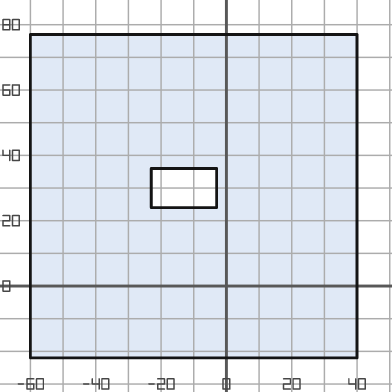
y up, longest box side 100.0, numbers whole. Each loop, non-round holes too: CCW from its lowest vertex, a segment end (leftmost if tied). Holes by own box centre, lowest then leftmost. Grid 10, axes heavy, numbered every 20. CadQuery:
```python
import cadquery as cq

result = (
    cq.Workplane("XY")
    .moveTo(-60.0, -22.0)
    .lineTo(40.0, -22.0)
    .lineTo(40.0, 77.0)
    .lineTo(-60.0, 77.0)
    .close()
    .moveTo(-23.0, 24.0)
    .lineTo(-3.0, 24.0)
    .lineTo(-3.0, 36.0)
    .lineTo(-23.0, 36.0)
    .close()
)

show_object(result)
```